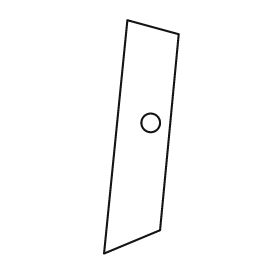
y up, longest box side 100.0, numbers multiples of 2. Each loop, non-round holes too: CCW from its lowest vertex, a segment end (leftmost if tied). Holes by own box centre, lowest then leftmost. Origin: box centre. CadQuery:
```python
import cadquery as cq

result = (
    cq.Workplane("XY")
    .moveTo(-16.0, -50.0)
    .lineTo(8.0, -40.0)
    .lineTo(16.0, 44.0)
    .lineTo(-6.0, 50.0)
    .close()
    .moveTo(4.0, 6.0)
    .circle(4.0)
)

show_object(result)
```